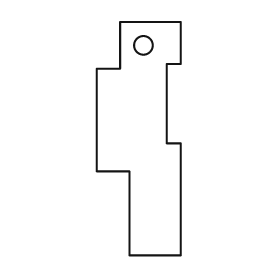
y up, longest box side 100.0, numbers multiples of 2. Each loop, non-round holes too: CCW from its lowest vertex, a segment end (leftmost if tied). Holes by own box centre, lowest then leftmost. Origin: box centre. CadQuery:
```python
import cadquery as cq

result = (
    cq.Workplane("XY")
    .moveTo(-4.0, -50.0)
    .lineTo(18.0, -50.0)
    .lineTo(18.0, -2.0)
    .lineTo(12.0, -2.0)
    .lineTo(12.0, 32.0)
    .lineTo(18.0, 32.0)
    .lineTo(18.0, 50.0)
    .lineTo(-8.0, 50.0)
    .lineTo(-8.0, 30.0)
    .lineTo(-18.0, 30.0)
    .lineTo(-18.0, -14.0)
    .lineTo(-4.0, -14.0)
    .close()
    .moveTo(2.0, 40.0)
    .circle(4.0)
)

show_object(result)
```